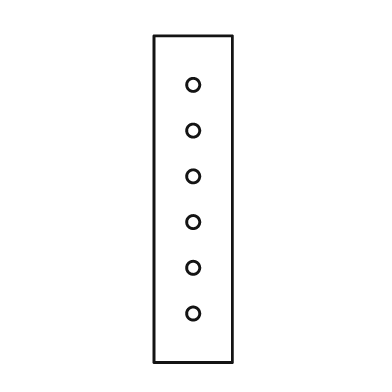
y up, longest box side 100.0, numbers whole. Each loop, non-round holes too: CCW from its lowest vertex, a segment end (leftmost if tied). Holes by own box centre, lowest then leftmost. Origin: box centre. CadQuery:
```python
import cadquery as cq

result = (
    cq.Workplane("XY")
    .moveTo(-12.0, -50.0)
    .lineTo(12.0, -50.0)
    .lineTo(12.0, 50.0)
    .lineTo(-12.0, 50.0)
    .close()
    .moveTo(0.0, -35.0)
    .circle(2.0)
    .moveTo(0.0, -21.0)
    .circle(2.0)
    .moveTo(0.0, -7.0)
    .circle(2.0)
    .moveTo(0.0, 7.0)
    .circle(2.0)
    .moveTo(0.0, 21.0)
    .circle(2.0)
    .moveTo(0.0, 35.0)
    .circle(2.0)
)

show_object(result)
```